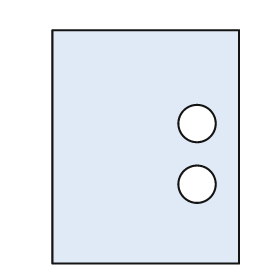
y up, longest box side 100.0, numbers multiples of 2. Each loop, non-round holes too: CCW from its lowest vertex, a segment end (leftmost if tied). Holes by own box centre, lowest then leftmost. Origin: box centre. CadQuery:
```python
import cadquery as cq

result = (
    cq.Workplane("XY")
    .moveTo(-40.0, -50.0)
    .lineTo(40.0, -50.0)
    .lineTo(40.0, 50.0)
    .lineTo(-40.0, 50.0)
    .close()
    .moveTo(22.0, -16.0)
    .circle(8.0)
    .moveTo(22.0, 10.0)
    .circle(8.0)
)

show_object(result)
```